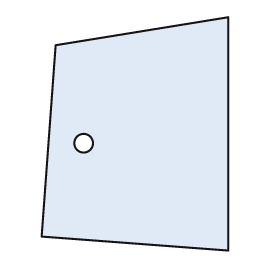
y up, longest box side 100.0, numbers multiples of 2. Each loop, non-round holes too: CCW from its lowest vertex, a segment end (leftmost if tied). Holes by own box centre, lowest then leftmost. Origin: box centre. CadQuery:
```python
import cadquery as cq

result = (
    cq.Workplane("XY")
    .moveTo(40.0, -50.0)
    .lineTo(40.0, 50.0)
    .lineTo(-34.0, 38.0)
    .lineTo(-40.0, -44.0)
    .close()
    .moveTo(-22.0, -4.0)
    .circle(4.0)
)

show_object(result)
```